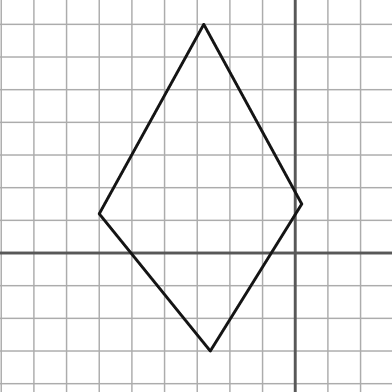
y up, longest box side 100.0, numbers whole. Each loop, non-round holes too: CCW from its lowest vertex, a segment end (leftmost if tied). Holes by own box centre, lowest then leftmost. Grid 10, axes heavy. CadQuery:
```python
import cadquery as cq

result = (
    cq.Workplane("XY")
    .moveTo(-26.0, -30.0)
    .lineTo(2.0, 15.0)
    .lineTo(-28.0, 70.0)
    .lineTo(-60.0, 12.0)
    .close()
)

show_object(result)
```